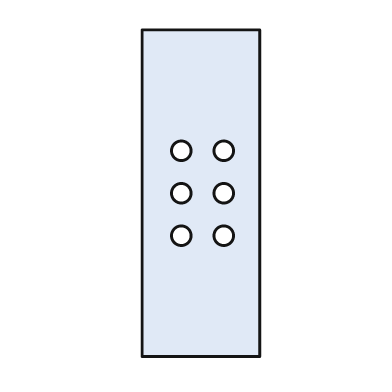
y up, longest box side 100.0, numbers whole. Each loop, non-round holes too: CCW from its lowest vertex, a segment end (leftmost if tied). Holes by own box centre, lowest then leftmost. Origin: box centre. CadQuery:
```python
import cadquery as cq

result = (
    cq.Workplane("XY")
    .moveTo(-18.0, -50.0)
    .lineTo(18.0, -50.0)
    .lineTo(18.0, 50.0)
    .lineTo(-18.0, 50.0)
    .close()
    .moveTo(-6.0, -13.0)
    .circle(3.0)
    .moveTo(7.0, -13.0)
    .circle(3.0)
    .moveTo(-6.0, 0.0)
    .circle(3.0)
    .moveTo(7.0, 0.0)
    .circle(3.0)
    .moveTo(-6.0, 13.0)
    .circle(3.0)
    .moveTo(7.0, 13.0)
    .circle(3.0)
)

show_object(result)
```